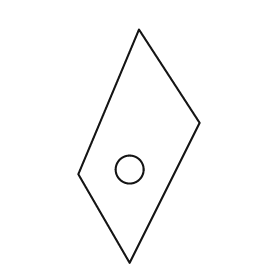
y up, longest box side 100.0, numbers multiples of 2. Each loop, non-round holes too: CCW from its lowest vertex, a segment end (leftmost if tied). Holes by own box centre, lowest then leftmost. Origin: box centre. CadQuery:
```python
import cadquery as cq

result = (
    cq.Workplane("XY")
    .moveTo(-4.0, -50.0)
    .lineTo(26.0, 10.0)
    .lineTo(0.0, 50.0)
    .lineTo(-26.0, -12.0)
    .close()
    .moveTo(-4.0, -10.0)
    .circle(6.0)
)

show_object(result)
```